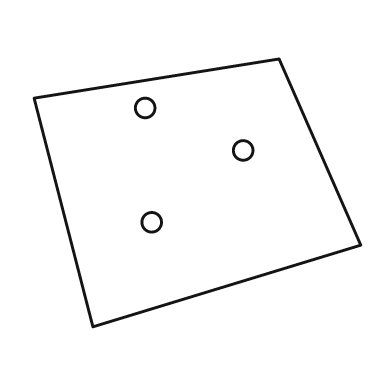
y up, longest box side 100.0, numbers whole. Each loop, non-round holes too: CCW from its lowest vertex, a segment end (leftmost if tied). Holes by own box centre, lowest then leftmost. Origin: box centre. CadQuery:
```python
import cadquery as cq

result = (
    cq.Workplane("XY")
    .moveTo(-32.0, -41.0)
    .lineTo(50.0, -16.0)
    .lineTo(25.0, 41.0)
    .lineTo(-50.0, 29.0)
    .close()
    .moveTo(-14.0, -9.0)
    .circle(3.0)
    .moveTo(14.0, 13.0)
    .circle(3.0)
    .moveTo(-16.0, 26.0)
    .circle(3.0)
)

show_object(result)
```